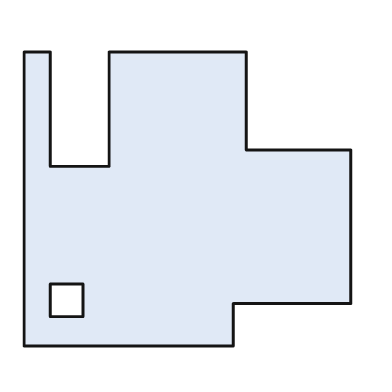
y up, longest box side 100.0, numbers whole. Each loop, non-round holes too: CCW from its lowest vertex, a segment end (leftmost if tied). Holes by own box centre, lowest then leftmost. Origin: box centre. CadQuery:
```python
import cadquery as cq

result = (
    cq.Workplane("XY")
    .moveTo(-50.0, -45.0)
    .lineTo(14.0, -45.0)
    .lineTo(14.0, -32.0)
    .lineTo(50.0, -32.0)
    .lineTo(50.0, 15.0)
    .lineTo(18.0, 15.0)
    .lineTo(18.0, 45.0)
    .lineTo(-24.0, 45.0)
    .lineTo(-24.0, 10.0)
    .lineTo(-42.0, 10.0)
    .lineTo(-42.0, 45.0)
    .lineTo(-50.0, 45.0)
    .close()
    .moveTo(-42.0, -36.0)
    .lineTo(-32.0, -36.0)
    .lineTo(-32.0, -26.0)
    .lineTo(-42.0, -26.0)
    .close()
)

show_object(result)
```